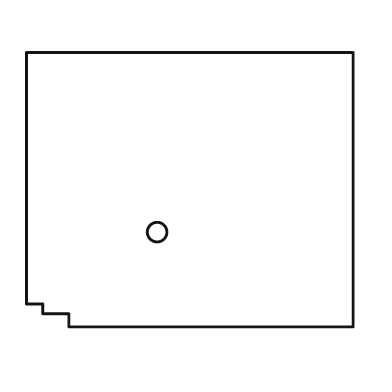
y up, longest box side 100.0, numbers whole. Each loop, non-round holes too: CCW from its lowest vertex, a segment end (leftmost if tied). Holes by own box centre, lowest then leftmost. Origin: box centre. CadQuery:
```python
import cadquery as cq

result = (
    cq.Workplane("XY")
    .moveTo(-37.0, -42.0)
    .lineTo(50.0, -42.0)
    .lineTo(50.0, 42.0)
    .lineTo(-50.0, 42.0)
    .lineTo(-50.0, -35.0)
    .lineTo(-45.0, -35.0)
    .lineTo(-45.0, -38.0)
    .lineTo(-37.0, -38.0)
    .close()
    .moveTo(-10.0, -13.0)
    .circle(3.0)
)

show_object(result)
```